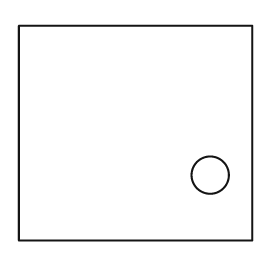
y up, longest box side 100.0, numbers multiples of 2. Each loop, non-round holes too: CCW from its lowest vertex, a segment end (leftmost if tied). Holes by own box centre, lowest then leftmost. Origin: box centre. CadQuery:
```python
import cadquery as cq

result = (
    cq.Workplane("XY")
    .moveTo(-50.0, -46.0)
    .lineTo(50.0, -46.0)
    .lineTo(50.0, 46.0)
    .lineTo(-50.0, 46.0)
    .close()
    .moveTo(32.0, -18.0)
    .circle(8.0)
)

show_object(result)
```